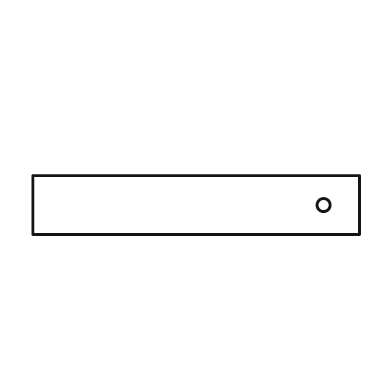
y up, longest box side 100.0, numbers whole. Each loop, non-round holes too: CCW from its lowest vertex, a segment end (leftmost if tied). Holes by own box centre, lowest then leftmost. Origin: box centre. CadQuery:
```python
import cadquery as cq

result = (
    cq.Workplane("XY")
    .moveTo(-50.0, -9.0)
    .lineTo(50.0, -9.0)
    .lineTo(50.0, 9.0)
    .lineTo(-50.0, 9.0)
    .close()
    .moveTo(39.0, 0.0)
    .circle(2.0)
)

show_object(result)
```